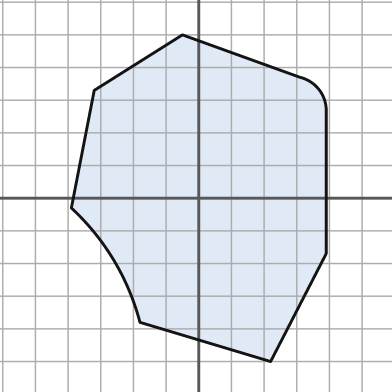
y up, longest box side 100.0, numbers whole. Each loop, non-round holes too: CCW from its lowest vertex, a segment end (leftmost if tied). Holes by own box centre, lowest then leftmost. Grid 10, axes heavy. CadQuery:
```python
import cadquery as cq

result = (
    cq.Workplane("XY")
    .moveTo(22.0, -50.0)
    .lineTo(39.0, -17.0)
    .lineTo(39.0, 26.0)
    .threePointArc((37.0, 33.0), (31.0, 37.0))
    .lineTo(-5.0, 50.0)
    .lineTo(-32.0, 33.0)
    .lineTo(-39.0, -3.0)
    .threePointArc((-26.0, -19.0), (-18.0, -38.0))
    .close()
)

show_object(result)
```